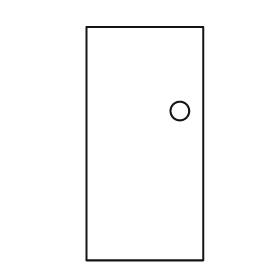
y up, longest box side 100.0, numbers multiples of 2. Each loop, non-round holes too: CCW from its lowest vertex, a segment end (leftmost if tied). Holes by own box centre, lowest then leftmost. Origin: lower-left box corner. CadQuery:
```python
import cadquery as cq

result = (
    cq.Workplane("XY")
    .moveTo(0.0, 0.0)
    .lineTo(50.0, 0.0)
    .lineTo(50.0, 100.0)
    .lineTo(0.0, 100.0)
    .close()
    .moveTo(40.0, 64.0)
    .circle(4.0)
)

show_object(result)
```